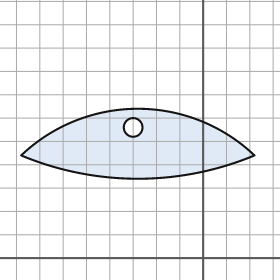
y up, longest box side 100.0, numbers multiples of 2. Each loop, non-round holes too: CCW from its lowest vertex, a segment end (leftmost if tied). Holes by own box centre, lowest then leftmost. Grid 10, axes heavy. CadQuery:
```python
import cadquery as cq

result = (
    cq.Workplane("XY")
    .moveTo(-78.0, 44.0)
    .threePointArc((-28.0, 34.0), (22.0, 44.0))
    .threePointArc((-28.0, 64.0), (-78.0, 44.0))
    .close()
    .moveTo(-30.0, 56.0)
    .circle(4.0)
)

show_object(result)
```